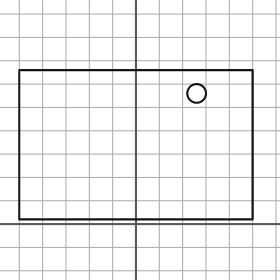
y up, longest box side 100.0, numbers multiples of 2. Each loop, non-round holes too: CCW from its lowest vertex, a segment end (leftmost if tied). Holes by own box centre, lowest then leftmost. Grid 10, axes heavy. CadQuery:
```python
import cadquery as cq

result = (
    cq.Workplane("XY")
    .moveTo(-50.0, 2.0)
    .lineTo(50.0, 2.0)
    .lineTo(50.0, 66.0)
    .lineTo(-50.0, 66.0)
    .close()
    .moveTo(26.0, 56.0)
    .circle(4.0)
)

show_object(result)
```